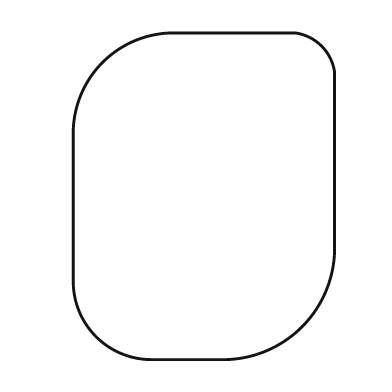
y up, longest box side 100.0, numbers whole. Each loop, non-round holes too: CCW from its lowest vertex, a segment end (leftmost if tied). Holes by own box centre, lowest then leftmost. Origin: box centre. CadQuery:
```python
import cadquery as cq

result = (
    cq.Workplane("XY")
    .moveTo(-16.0, -50.0)
    .lineTo(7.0, -50.0)
    .threePointArc((30.0, -40.0), (40.0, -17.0))
    .lineTo(40.0, 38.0)
    .threePointArc((36.0, 46.0), (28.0, 50.0))
    .lineTo(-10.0, 50.0)
    .threePointArc((-31.0, 41.0), (-40.0, 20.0))
    .lineTo(-40.0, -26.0)
    .threePointArc((-33.0, -43.0), (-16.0, -50.0))
    .close()
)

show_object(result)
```